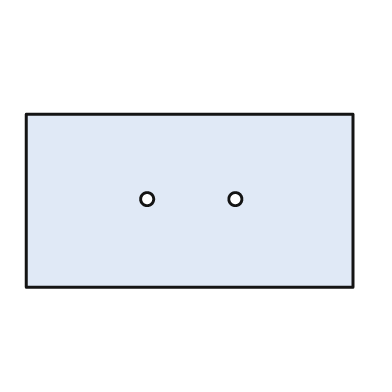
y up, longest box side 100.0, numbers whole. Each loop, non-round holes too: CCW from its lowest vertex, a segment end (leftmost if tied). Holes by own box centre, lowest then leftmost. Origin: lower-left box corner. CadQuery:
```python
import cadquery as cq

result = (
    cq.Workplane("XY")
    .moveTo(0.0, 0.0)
    .lineTo(100.0, 0.0)
    .lineTo(100.0, 53.0)
    .lineTo(0.0, 53.0)
    .close()
    .moveTo(37.0, 27.0)
    .circle(2.0)
    .moveTo(64.0, 27.0)
    .circle(2.0)
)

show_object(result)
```